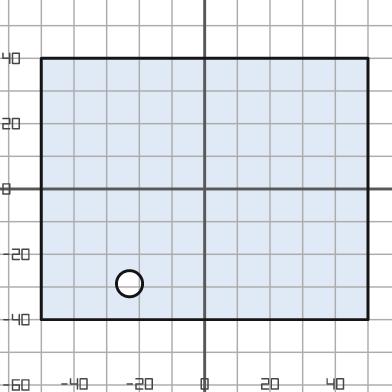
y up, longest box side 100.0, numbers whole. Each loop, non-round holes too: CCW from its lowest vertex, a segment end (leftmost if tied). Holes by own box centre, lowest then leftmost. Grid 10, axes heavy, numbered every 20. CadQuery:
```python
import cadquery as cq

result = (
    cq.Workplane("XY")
    .moveTo(-50.0, -40.0)
    .lineTo(50.0, -40.0)
    .lineTo(50.0, 40.0)
    .lineTo(-50.0, 40.0)
    .close()
    .moveTo(-23.0, -29.0)
    .circle(4.0)
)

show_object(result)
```